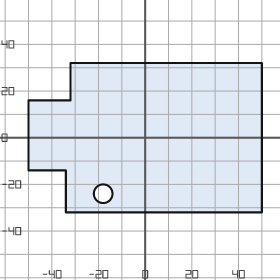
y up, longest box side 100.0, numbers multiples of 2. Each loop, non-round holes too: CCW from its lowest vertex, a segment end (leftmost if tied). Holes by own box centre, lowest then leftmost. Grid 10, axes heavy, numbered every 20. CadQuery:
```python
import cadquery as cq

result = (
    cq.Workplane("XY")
    .moveTo(-34.0, -32.0)
    .lineTo(50.0, -32.0)
    .lineTo(50.0, 32.0)
    .lineTo(-32.0, 32.0)
    .lineTo(-32.0, 16.0)
    .lineTo(-50.0, 16.0)
    .lineTo(-50.0, -14.0)
    .lineTo(-34.0, -14.0)
    .close()
    .moveTo(-18.0, -24.0)
    .circle(4.0)
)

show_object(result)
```